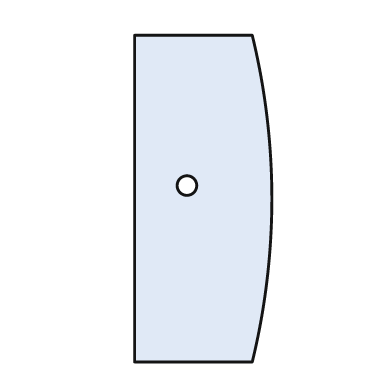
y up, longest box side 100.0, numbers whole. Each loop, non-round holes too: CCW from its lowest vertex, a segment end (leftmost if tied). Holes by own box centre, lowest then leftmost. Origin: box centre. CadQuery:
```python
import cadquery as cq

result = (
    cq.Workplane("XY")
    .moveTo(-21.0, -50.0)
    .lineTo(15.0, -50.0)
    .threePointArc((21.0, 0.0), (15.0, 50.0))
    .lineTo(-21.0, 50.0)
    .close()
    .moveTo(-5.0, 4.0)
    .circle(3.0)
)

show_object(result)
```